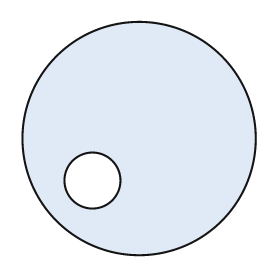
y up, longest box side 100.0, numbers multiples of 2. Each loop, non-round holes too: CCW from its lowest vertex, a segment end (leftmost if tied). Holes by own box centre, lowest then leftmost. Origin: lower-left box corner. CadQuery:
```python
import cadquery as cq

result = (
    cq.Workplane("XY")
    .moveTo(50.0, 50.0)
    .circle(50.0)
    .moveTo(30.0, 32.0)
    .circle(12.0)
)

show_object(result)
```